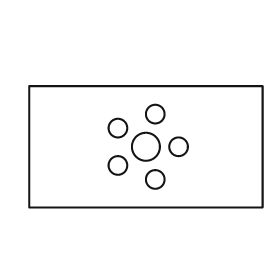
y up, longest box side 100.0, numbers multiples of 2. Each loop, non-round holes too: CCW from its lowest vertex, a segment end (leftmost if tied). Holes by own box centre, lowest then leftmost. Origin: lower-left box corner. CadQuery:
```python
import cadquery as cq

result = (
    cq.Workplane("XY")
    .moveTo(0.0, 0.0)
    .lineTo(100.0, 0.0)
    .lineTo(100.0, 52.0)
    .lineTo(0.0, 52.0)
    .close()
    .moveTo(54.0, 12.0)
    .circle(4.0)
    .moveTo(38.0, 18.0)
    .circle(4.0)
    .moveTo(50.0, 26.0)
    .circle(6.0)
    .moveTo(64.0, 26.0)
    .circle(4.0)
    .moveTo(38.0, 34.0)
    .circle(4.0)
    .moveTo(54.0, 40.0)
    .circle(4.0)
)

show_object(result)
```